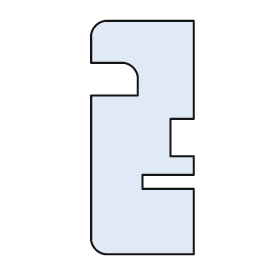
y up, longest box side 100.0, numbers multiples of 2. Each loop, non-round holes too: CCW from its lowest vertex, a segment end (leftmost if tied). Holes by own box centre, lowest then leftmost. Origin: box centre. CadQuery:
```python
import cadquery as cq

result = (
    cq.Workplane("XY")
    .moveTo(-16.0, -50.0)
    .lineTo(22.0, -50.0)
    .lineTo(22.0, -22.0)
    .lineTo(0.0, -22.0)
    .lineTo(0.0, -16.0)
    .lineTo(22.0, -16.0)
    .lineTo(22.0, -8.0)
    .lineTo(12.0, -8.0)
    .lineTo(12.0, 8.0)
    .lineTo(22.0, 8.0)
    .lineTo(22.0, 50.0)
    .lineTo(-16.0, 50.0)
    .threePointArc((-20.0, 48.0), (-22.0, 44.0))
    .lineTo(-22.0, 32.0)
    .lineTo(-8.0, 32.0)
    .threePointArc((-4.0, 30.0), (-2.0, 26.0))
    .lineTo(-2.0, 18.0)
    .lineTo(-22.0, 18.0)
    .lineTo(-22.0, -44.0)
    .threePointArc((-20.0, -48.0), (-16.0, -50.0))
    .close()
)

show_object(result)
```